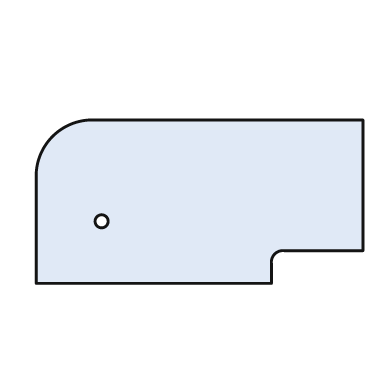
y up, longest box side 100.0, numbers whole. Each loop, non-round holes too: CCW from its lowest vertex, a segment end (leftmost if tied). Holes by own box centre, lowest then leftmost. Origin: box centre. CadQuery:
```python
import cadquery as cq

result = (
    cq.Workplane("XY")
    .moveTo(-50.0, -25.0)
    .lineTo(22.0, -25.0)
    .lineTo(22.0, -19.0)
    .threePointArc((23.0, -16.0), (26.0, -15.0))
    .lineTo(50.0, -15.0)
    .lineTo(50.0, 25.0)
    .lineTo(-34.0, 25.0)
    .threePointArc((-45.0, 20.0), (-50.0, 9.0))
    .close()
    .moveTo(-30.0, -6.0)
    .circle(2.0)
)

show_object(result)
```